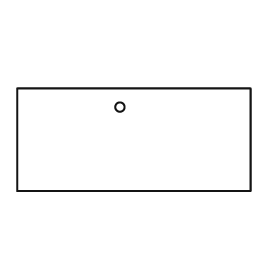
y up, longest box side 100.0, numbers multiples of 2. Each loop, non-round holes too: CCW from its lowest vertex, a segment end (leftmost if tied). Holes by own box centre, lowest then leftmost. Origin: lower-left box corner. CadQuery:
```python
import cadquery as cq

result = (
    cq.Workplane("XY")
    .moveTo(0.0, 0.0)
    .lineTo(100.0, 0.0)
    .lineTo(100.0, 44.0)
    .lineTo(0.0, 44.0)
    .close()
    .moveTo(44.0, 36.0)
    .circle(2.0)
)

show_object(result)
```